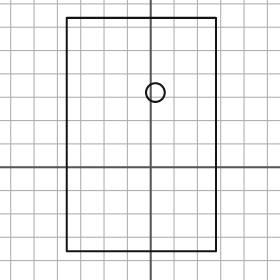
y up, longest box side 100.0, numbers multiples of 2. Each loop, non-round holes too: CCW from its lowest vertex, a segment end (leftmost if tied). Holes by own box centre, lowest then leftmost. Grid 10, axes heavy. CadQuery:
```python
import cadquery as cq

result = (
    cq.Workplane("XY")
    .moveTo(-36.0, -36.0)
    .lineTo(28.0, -36.0)
    .lineTo(28.0, 64.0)
    .lineTo(-36.0, 64.0)
    .close()
    .moveTo(2.0, 32.0)
    .circle(4.0)
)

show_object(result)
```